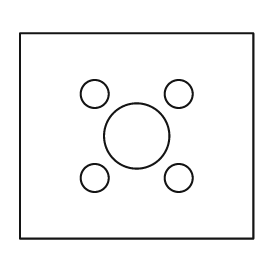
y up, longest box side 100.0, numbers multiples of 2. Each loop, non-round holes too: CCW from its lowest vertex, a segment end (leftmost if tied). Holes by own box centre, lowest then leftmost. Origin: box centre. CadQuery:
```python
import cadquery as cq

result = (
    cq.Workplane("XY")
    .moveTo(-50.0, -44.0)
    .lineTo(50.0, -44.0)
    .lineTo(50.0, 44.0)
    .lineTo(-50.0, 44.0)
    .close()
    .moveTo(-18.0, -18.0)
    .circle(6.0)
    .moveTo(18.0, -18.0)
    .circle(6.0)
    .moveTo(0.0, 0.0)
    .circle(14.0)
    .moveTo(-18.0, 18.0)
    .circle(6.0)
    .moveTo(18.0, 18.0)
    .circle(6.0)
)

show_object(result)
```